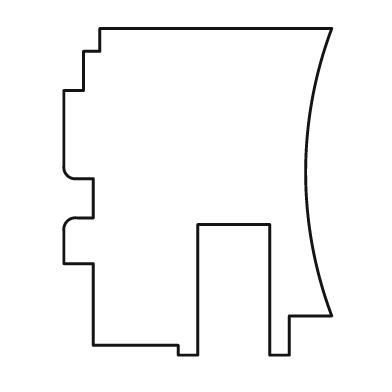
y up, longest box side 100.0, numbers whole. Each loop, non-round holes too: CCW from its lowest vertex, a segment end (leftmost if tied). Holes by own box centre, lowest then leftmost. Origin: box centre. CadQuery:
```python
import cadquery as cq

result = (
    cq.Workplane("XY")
    .moveTo(-6.0, -50.0)
    .lineTo(0.0, -50.0)
    .lineTo(0.0, -10.0)
    .lineTo(22.0, -10.0)
    .lineTo(22.0, -50.0)
    .lineTo(28.0, -50.0)
    .lineTo(28.0, -38.0)
    .lineTo(41.0, -38.0)
    .threePointArc((33.0, 6.0), (41.0, 50.0))
    .lineTo(-30.0, 50.0)
    .lineTo(-30.0, 43.0)
    .lineTo(-35.0, 43.0)
    .lineTo(-35.0, 31.0)
    .lineTo(-41.0, 31.0)
    .lineTo(-41.0, 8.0)
    .threePointArc((-40.0, 5.0), (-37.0, 4.0))
    .lineTo(-32.0, 4.0)
    .lineTo(-32.0, -8.0)
    .lineTo(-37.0, -8.0)
    .threePointArc((-40.0, -9.0), (-41.0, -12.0))
    .lineTo(-41.0, -22.0)
    .lineTo(-32.0, -22.0)
    .lineTo(-32.0, -47.0)
    .lineTo(-6.0, -47.0)
    .close()
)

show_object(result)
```